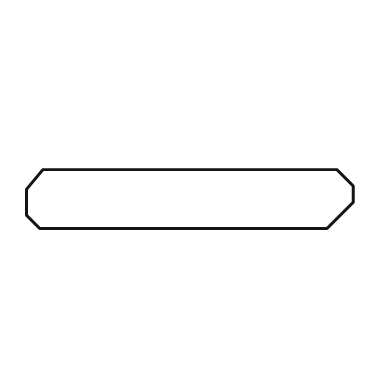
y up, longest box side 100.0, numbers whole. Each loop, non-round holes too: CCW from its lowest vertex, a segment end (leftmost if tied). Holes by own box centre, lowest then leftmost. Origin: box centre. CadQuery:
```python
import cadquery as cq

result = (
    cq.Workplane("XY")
    .moveTo(-46.0, -9.0)
    .lineTo(42.0, -9.0)
    .lineTo(50.0, -1.0)
    .lineTo(50.0, 4.0)
    .lineTo(45.0, 9.0)
    .lineTo(-45.0, 9.0)
    .lineTo(-50.0, 3.0)
    .lineTo(-50.0, -5.0)
    .close()
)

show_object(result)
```